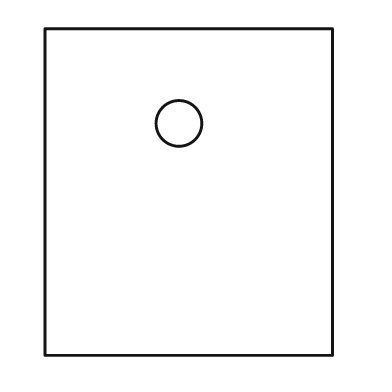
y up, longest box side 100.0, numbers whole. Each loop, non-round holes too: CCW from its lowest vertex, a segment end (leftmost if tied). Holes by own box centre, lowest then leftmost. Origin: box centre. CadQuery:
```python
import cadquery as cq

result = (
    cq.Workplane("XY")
    .moveTo(-44.0, -50.0)
    .lineTo(44.0, -50.0)
    .lineTo(44.0, 50.0)
    .lineTo(-44.0, 50.0)
    .close()
    .moveTo(-3.0, 21.0)
    .circle(7.0)
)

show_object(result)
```